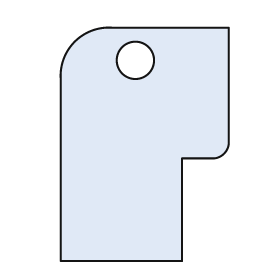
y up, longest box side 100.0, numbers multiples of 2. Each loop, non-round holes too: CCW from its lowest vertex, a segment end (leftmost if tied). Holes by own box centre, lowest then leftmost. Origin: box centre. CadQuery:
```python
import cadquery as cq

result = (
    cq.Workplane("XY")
    .moveTo(-36.0, -50.0)
    .lineTo(16.0, -50.0)
    .lineTo(16.0, -6.0)
    .lineTo(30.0, -6.0)
    .threePointArc((34.0, -4.0), (36.0, 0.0))
    .lineTo(36.0, 50.0)
    .lineTo(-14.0, 50.0)
    .threePointArc((-30.0, 44.0), (-36.0, 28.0))
    .close()
    .moveTo(-4.0, 36.0)
    .circle(8.0)
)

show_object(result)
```